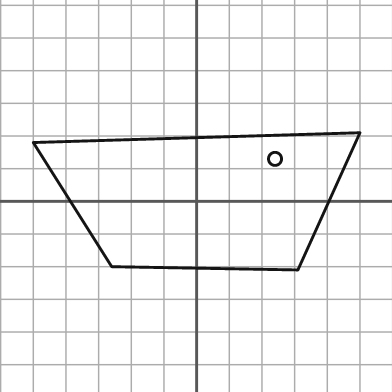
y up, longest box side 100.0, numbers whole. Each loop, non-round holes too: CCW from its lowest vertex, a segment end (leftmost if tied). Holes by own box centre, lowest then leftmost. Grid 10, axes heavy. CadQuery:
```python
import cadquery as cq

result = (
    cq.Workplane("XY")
    .moveTo(31.0, -21.0)
    .lineTo(50.0, 21.0)
    .lineTo(-50.0, 18.0)
    .lineTo(-26.0, -20.0)
    .close()
    .moveTo(24.0, 13.0)
    .circle(2.0)
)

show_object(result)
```